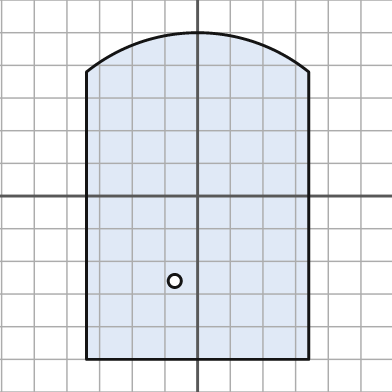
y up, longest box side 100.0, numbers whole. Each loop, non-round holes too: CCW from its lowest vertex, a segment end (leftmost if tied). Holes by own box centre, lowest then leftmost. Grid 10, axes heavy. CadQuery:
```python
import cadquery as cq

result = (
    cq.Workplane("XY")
    .moveTo(-34.0, -50.0)
    .lineTo(34.0, -50.0)
    .lineTo(34.0, 38.0)
    .threePointArc((0.0, 50.0), (-34.0, 38.0))
    .close()
    .moveTo(-7.0, -26.0)
    .circle(2.0)
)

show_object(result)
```